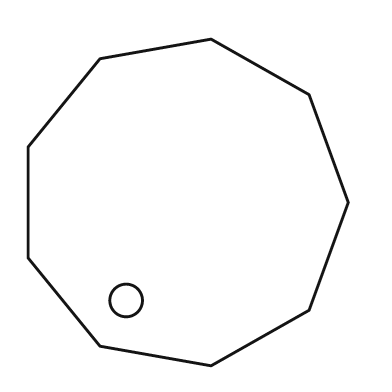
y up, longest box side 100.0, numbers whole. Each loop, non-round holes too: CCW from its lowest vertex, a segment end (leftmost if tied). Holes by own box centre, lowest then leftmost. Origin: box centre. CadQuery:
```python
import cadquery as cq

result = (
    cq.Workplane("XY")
    .moveTo(7.0, -50.0)
    .lineTo(37.0, -33.0)
    .lineTo(49.0, 0.0)
    .lineTo(37.0, 33.0)
    .lineTo(7.0, 50.0)
    .lineTo(-27.0, 44.0)
    .lineTo(-49.0, 17.0)
    .lineTo(-49.0, -17.0)
    .lineTo(-27.0, -44.0)
    .close()
    .moveTo(-19.0, -30.0)
    .circle(5.0)
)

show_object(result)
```